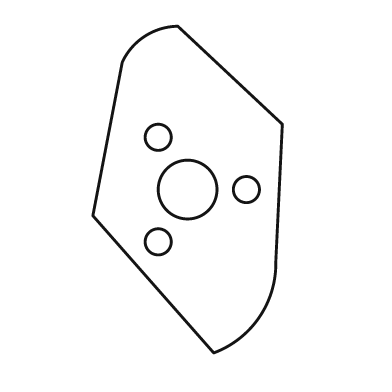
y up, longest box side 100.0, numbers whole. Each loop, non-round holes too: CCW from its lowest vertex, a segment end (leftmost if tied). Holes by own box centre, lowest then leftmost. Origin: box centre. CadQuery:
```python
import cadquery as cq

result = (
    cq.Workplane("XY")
    .moveTo(8.0, -50.0)
    .threePointArc((22.0, -39.0), (27.0, -22.0))
    .lineTo(29.0, 20.0)
    .lineTo(-3.0, 50.0)
    .threePointArc((-13.0, 47.0), (-20.0, 39.0))
    .lineTo(-29.0, -8.0)
    .close()
    .moveTo(-9.0, -16.0)
    .circle(4.0)
    .moveTo(0.0, 0.0)
    .circle(9.0)
    .moveTo(18.0, 0.0)
    .circle(4.0)
    .moveTo(-9.0, 16.0)
    .circle(4.0)
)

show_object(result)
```